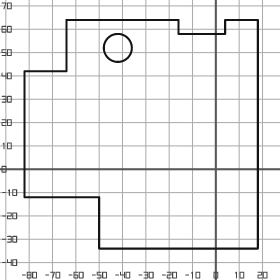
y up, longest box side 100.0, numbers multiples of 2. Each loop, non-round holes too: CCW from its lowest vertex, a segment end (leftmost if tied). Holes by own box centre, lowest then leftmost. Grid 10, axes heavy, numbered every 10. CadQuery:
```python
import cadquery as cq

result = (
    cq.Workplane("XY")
    .moveTo(-50.0, -34.0)
    .lineTo(18.0, -34.0)
    .lineTo(18.0, 64.0)
    .lineTo(4.0, 64.0)
    .lineTo(4.0, 58.0)
    .lineTo(-16.0, 58.0)
    .lineTo(-16.0, 64.0)
    .lineTo(-64.0, 64.0)
    .lineTo(-64.0, 42.0)
    .lineTo(-82.0, 42.0)
    .lineTo(-82.0, -12.0)
    .lineTo(-50.0, -12.0)
    .close()
    .moveTo(-42.0, 52.0)
    .circle(6.0)
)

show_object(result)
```